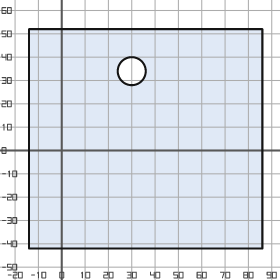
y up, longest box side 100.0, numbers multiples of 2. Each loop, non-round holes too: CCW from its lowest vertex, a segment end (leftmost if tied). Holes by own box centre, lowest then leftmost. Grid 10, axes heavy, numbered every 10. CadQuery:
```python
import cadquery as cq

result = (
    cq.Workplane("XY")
    .moveTo(-14.0, -42.0)
    .lineTo(86.0, -42.0)
    .lineTo(86.0, 52.0)
    .lineTo(-14.0, 52.0)
    .close()
    .moveTo(30.0, 34.0)
    .circle(6.0)
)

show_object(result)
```